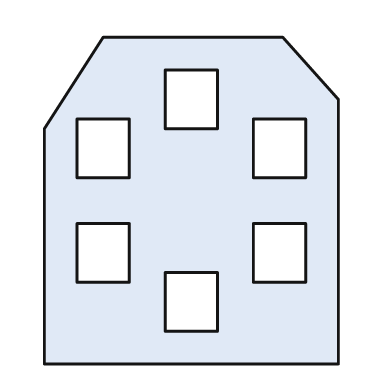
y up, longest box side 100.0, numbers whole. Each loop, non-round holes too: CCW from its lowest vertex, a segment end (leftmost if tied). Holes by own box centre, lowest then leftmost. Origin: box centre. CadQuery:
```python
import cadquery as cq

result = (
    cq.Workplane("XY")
    .moveTo(-45.0, -50.0)
    .lineTo(45.0, -50.0)
    .lineTo(45.0, 31.0)
    .lineTo(28.0, 50.0)
    .lineTo(-27.0, 50.0)
    .lineTo(-45.0, 22.0)
    .close()
    .moveTo(-8.0, -40.0)
    .lineTo(8.0, -40.0)
    .lineTo(8.0, -22.0)
    .lineTo(-8.0, -22.0)
    .close()
    .moveTo(-35.0, -25.0)
    .lineTo(-19.0, -25.0)
    .lineTo(-19.0, -7.0)
    .lineTo(-35.0, -7.0)
    .close()
    .moveTo(19.0, -25.0)
    .lineTo(35.0, -25.0)
    .lineTo(35.0, -7.0)
    .lineTo(19.0, -7.0)
    .close()
    .moveTo(-35.0, 7.0)
    .lineTo(-19.0, 7.0)
    .lineTo(-19.0, 25.0)
    .lineTo(-35.0, 25.0)
    .close()
    .moveTo(19.0, 7.0)
    .lineTo(35.0, 7.0)
    .lineTo(35.0, 25.0)
    .lineTo(19.0, 25.0)
    .close()
    .moveTo(-8.0, 22.0)
    .lineTo(8.0, 22.0)
    .lineTo(8.0, 40.0)
    .lineTo(-8.0, 40.0)
    .close()
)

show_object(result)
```